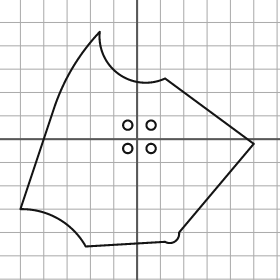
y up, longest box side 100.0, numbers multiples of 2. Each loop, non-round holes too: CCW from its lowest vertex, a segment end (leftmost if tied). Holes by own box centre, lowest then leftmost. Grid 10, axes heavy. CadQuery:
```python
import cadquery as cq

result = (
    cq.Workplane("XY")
    .moveTo(-22.0, -46.0)
    .lineTo(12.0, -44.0)
    .threePointArc((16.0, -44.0), (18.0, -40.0))
    .lineTo(50.0, -2.0)
    .lineTo(12.0, 26.0)
    .threePointArc((-8.0, 28.0), (-16.0, 46.0))
    .threePointArc((-28.0, 30.0), (-36.0, 12.0))
    .lineTo(-50.0, -30.0)
    .threePointArc((-34.0, -34.0), (-22.0, -46.0))
    .close()
    .moveTo(-4.0, -4.0)
    .circle(2.0)
    .moveTo(6.0, -4.0)
    .circle(2.0)
    .moveTo(-4.0, 6.0)
    .circle(2.0)
    .moveTo(6.0, 6.0)
    .circle(2.0)
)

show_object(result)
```